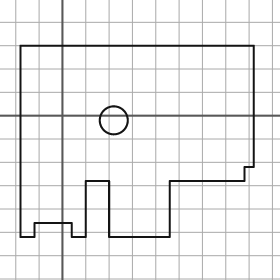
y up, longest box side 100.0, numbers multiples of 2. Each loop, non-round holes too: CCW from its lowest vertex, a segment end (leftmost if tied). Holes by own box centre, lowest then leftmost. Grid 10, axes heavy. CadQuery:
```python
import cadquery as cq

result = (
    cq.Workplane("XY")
    .moveTo(-18.0, -52.0)
    .lineTo(-12.0, -52.0)
    .lineTo(-12.0, -46.0)
    .lineTo(4.0, -46.0)
    .lineTo(4.0, -52.0)
    .lineTo(10.0, -52.0)
    .lineTo(10.0, -28.0)
    .lineTo(20.0, -28.0)
    .lineTo(20.0, -52.0)
    .lineTo(46.0, -52.0)
    .lineTo(46.0, -28.0)
    .lineTo(78.0, -28.0)
    .lineTo(78.0, -22.0)
    .lineTo(82.0, -22.0)
    .lineTo(82.0, 30.0)
    .lineTo(-18.0, 30.0)
    .close()
    .moveTo(22.0, -2.0)
    .circle(6.0)
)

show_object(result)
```